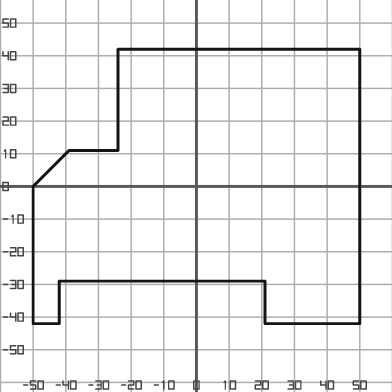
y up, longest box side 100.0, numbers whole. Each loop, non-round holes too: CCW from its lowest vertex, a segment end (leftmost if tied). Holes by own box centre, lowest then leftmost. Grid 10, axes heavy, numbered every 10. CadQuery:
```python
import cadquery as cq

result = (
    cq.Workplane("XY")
    .moveTo(-50.0, -42.0)
    .lineTo(-42.0, -42.0)
    .lineTo(-42.0, -29.0)
    .lineTo(21.0, -29.0)
    .lineTo(21.0, -42.0)
    .lineTo(50.0, -42.0)
    .lineTo(50.0, 42.0)
    .lineTo(-24.0, 42.0)
    .lineTo(-24.0, 11.0)
    .lineTo(-39.0, 11.0)
    .lineTo(-50.0, 0.0)
    .close()
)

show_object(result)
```